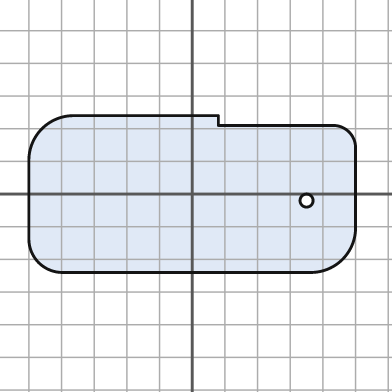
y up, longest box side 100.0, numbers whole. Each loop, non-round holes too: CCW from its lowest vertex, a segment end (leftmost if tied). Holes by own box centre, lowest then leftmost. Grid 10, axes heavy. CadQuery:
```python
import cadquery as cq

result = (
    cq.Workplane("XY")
    .moveTo(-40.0, -24.0)
    .lineTo(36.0, -24.0)
    .threePointArc((46.0, -20.0), (50.0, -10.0))
    .lineTo(50.0, 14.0)
    .threePointArc((48.0, 19.0), (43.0, 21.0))
    .lineTo(8.0, 21.0)
    .lineTo(8.0, 24.0)
    .lineTo(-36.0, 24.0)
    .threePointArc((-46.0, 20.0), (-50.0, 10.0))
    .lineTo(-50.0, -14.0)
    .threePointArc((-47.0, -21.0), (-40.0, -24.0))
    .close()
    .moveTo(35.0, -2.0)
    .circle(2.0)
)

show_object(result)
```